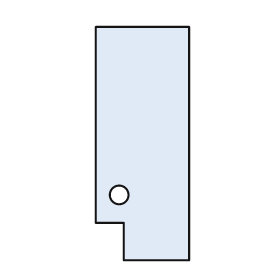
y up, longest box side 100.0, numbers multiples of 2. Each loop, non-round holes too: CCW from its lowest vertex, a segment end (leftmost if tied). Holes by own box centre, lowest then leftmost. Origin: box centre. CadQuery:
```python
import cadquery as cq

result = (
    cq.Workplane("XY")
    .moveTo(-8.0, -50.0)
    .lineTo(20.0, -50.0)
    .lineTo(20.0, 50.0)
    .lineTo(-20.0, 50.0)
    .lineTo(-20.0, -34.0)
    .lineTo(-8.0, -34.0)
    .close()
    .moveTo(-10.0, -22.0)
    .circle(4.0)
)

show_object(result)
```